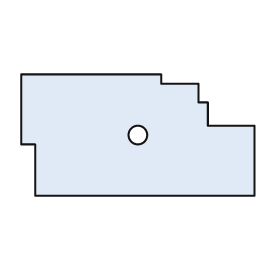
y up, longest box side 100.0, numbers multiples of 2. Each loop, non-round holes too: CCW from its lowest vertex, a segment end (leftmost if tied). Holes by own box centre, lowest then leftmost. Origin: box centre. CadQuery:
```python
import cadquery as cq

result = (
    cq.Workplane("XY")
    .moveTo(-44.0, -26.0)
    .lineTo(50.0, -26.0)
    .lineTo(50.0, 4.0)
    .lineTo(30.0, 4.0)
    .lineTo(30.0, 14.0)
    .lineTo(26.0, 14.0)
    .lineTo(26.0, 22.0)
    .lineTo(10.0, 22.0)
    .lineTo(10.0, 26.0)
    .lineTo(-50.0, 26.0)
    .lineTo(-50.0, -4.0)
    .lineTo(-44.0, -4.0)
    .close()
    .moveTo(0.0, 0.0)
    .circle(4.0)
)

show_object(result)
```